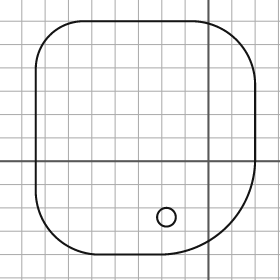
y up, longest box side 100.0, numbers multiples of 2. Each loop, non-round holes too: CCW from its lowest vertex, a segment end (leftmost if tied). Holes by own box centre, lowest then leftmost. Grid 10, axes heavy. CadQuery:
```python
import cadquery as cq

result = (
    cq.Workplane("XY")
    .moveTo(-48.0, -40.0)
    .lineTo(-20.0, -40.0)
    .threePointArc((8.0, -28.0), (20.0, 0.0))
    .lineTo(20.0, 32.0)
    .threePointArc((12.0, 52.0), (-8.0, 60.0))
    .lineTo(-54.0, 60.0)
    .threePointArc((-68.0, 54.0), (-74.0, 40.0))
    .lineTo(-74.0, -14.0)
    .threePointArc((-66.0, -32.0), (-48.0, -40.0))
    .close()
    .moveTo(-18.0, -24.0)
    .circle(4.0)
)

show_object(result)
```